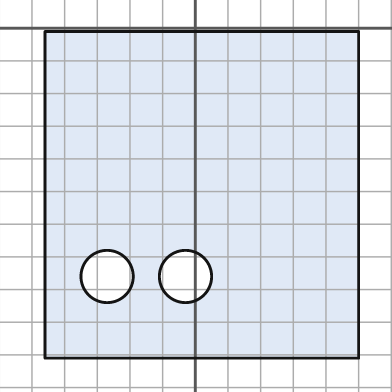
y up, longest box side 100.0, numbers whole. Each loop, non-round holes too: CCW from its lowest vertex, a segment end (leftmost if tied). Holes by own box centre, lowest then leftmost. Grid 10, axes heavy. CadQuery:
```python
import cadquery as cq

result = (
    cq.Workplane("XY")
    .moveTo(-46.0, -101.0)
    .lineTo(50.0, -101.0)
    .lineTo(50.0, -1.0)
    .lineTo(-46.0, -1.0)
    .close()
    .moveTo(-27.0, -76.0)
    .circle(8.0)
    .moveTo(-3.0, -76.0)
    .circle(8.0)
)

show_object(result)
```